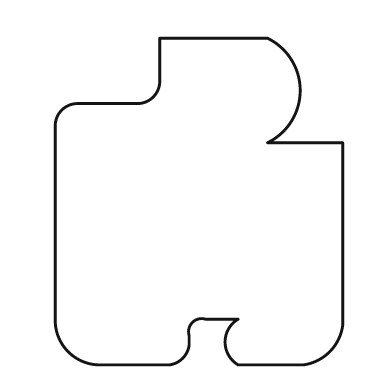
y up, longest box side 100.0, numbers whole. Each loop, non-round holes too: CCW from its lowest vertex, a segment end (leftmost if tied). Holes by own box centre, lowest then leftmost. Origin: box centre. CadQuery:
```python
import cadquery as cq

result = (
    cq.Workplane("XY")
    .moveTo(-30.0, -50.0)
    .lineTo(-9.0, -50.0)
    .threePointArc((-5.0, -48.0), (-3.0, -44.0))
    .lineTo(-3.0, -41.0)
    .threePointArc((-2.0, -37.0), (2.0, -36.0))
    .lineTo(12.0, -36.0)
    .threePointArc((8.0, -43.0), (12.0, -50.0))
    .lineTo(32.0, -50.0)
    .threePointArc((40.0, -46.0), (44.0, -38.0))
    .lineTo(44.0, 18.0)
    .lineTo(21.0, 18.0)
    .threePointArc((31.0, 34.0), (21.0, 50.0))
    .lineTo(-12.0, 50.0)
    .lineTo(-12.0, 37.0)
    .threePointArc((-14.0, 32.0), (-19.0, 30.0))
    .lineTo(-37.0, 30.0)
    .threePointArc((-42.0, 28.0), (-44.0, 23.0))
    .lineTo(-44.0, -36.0)
    .threePointArc((-40.0, -46.0), (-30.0, -50.0))
    .close()
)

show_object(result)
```